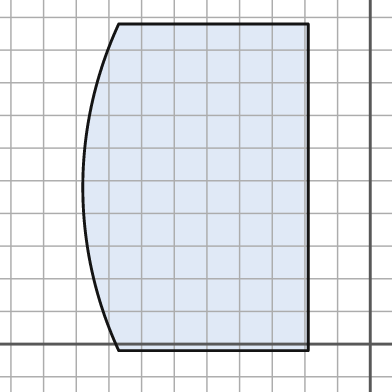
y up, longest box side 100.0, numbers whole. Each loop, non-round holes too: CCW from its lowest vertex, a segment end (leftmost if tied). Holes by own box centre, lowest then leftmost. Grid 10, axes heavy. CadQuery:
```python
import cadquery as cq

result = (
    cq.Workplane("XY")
    .moveTo(-77.0, -2.0)
    .lineTo(-19.0, -2.0)
    .lineTo(-19.0, 98.0)
    .lineTo(-77.0, 98.0)
    .threePointArc((-88.0, 48.0), (-77.0, -2.0))
    .close()
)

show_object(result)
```